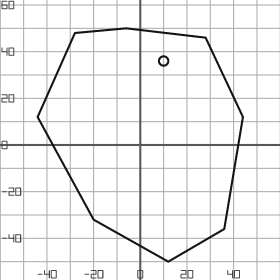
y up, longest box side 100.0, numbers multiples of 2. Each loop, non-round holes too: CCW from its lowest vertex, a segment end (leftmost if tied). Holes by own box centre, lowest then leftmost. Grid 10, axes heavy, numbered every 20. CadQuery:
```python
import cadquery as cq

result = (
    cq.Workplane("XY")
    .moveTo(12.0, -50.0)
    .lineTo(36.0, -36.0)
    .lineTo(44.0, 12.0)
    .lineTo(28.0, 46.0)
    .lineTo(-6.0, 50.0)
    .lineTo(-28.0, 48.0)
    .lineTo(-44.0, 12.0)
    .lineTo(-20.0, -32.0)
    .close()
    .moveTo(10.0, 36.0)
    .circle(2.0)
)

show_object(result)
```